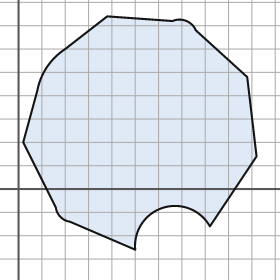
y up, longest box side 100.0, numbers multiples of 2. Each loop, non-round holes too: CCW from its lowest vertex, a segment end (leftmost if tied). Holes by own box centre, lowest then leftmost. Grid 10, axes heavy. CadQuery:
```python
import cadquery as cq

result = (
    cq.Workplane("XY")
    .moveTo(50.0, -26.0)
    .threePointArc((62.0, -8.0), (82.0, -16.0))
    .lineTo(102.0, 14.0)
    .lineTo(98.0, 48.0)
    .lineTo(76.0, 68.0)
    .threePointArc((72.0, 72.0), (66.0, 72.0))
    .lineTo(38.0, 74.0)
    .lineTo(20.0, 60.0)
    .threePointArc((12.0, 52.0), (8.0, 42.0))
    .lineTo(2.0, 20.0)
    .lineTo(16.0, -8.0)
    .threePointArc((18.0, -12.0), (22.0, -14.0))
    .close()
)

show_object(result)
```